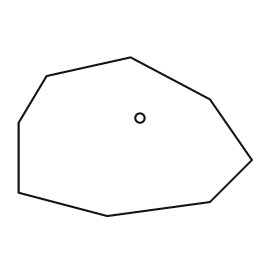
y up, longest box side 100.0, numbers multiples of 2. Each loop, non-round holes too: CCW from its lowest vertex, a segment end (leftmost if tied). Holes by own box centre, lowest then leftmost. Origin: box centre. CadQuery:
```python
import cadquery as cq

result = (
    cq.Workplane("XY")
    .moveTo(-12.0, -34.0)
    .lineTo(32.0, -28.0)
    .lineTo(50.0, -10.0)
    .lineTo(32.0, 16.0)
    .lineTo(-2.0, 34.0)
    .lineTo(-38.0, 26.0)
    .lineTo(-50.0, 6.0)
    .lineTo(-50.0, -24.0)
    .close()
    .moveTo(2.0, 8.0)
    .circle(2.0)
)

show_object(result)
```